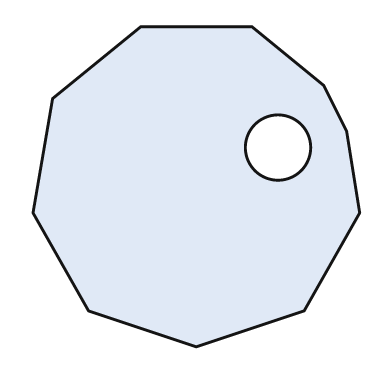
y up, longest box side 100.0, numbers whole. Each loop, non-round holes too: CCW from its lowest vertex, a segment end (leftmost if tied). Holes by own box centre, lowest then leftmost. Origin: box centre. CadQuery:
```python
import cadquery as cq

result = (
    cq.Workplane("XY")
    .moveTo(0.0, -49.0)
    .lineTo(33.0, -38.0)
    .lineTo(50.0, -8.0)
    .lineTo(46.0, 17.0)
    .lineTo(39.0, 31.0)
    .lineTo(17.0, 49.0)
    .lineTo(-17.0, 49.0)
    .lineTo(-44.0, 27.0)
    .lineTo(-50.0, -8.0)
    .lineTo(-33.0, -38.0)
    .close()
    .moveTo(25.0, 12.0)
    .circle(10.0)
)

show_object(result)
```